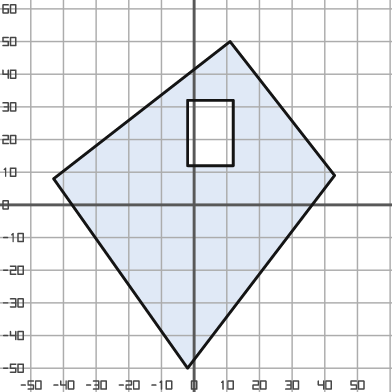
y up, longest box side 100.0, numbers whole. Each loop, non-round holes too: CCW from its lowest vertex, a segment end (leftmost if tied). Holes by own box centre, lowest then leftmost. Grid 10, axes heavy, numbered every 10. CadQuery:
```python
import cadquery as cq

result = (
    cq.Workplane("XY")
    .moveTo(-2.0, -50.0)
    .lineTo(43.0, 9.0)
    .lineTo(11.0, 50.0)
    .lineTo(-43.0, 8.0)
    .close()
    .moveTo(-2.0, 12.0)
    .lineTo(12.0, 12.0)
    .lineTo(12.0, 32.0)
    .lineTo(-2.0, 32.0)
    .close()
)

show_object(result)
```